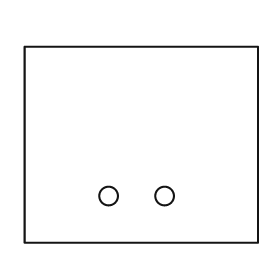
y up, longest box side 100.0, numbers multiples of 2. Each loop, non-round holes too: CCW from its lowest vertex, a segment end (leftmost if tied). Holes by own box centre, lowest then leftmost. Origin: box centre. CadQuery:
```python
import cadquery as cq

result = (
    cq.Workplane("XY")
    .moveTo(-50.0, -42.0)
    .lineTo(50.0, -42.0)
    .lineTo(50.0, 42.0)
    .lineTo(-50.0, 42.0)
    .close()
    .moveTo(-14.0, -22.0)
    .circle(4.0)
    .moveTo(10.0, -22.0)
    .circle(4.0)
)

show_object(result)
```